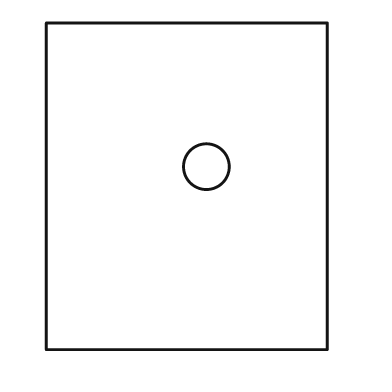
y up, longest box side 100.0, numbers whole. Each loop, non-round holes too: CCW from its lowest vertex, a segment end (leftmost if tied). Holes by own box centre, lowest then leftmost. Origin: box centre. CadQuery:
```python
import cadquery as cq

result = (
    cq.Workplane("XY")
    .moveTo(-43.0, -50.0)
    .lineTo(43.0, -50.0)
    .lineTo(43.0, 50.0)
    .lineTo(-43.0, 50.0)
    .close()
    .moveTo(6.0, 6.0)
    .circle(7.0)
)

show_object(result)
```